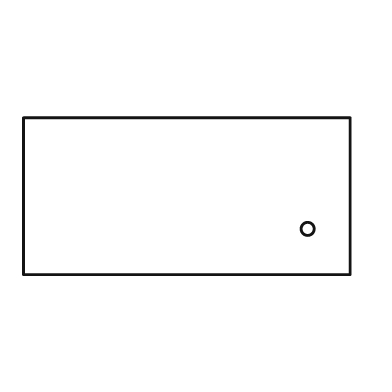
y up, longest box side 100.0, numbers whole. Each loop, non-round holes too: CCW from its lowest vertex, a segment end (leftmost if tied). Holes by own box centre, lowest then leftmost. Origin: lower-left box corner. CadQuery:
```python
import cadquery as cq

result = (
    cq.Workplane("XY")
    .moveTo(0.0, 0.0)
    .lineTo(100.0, 0.0)
    .lineTo(100.0, 48.0)
    .lineTo(0.0, 48.0)
    .close()
    .moveTo(87.0, 14.0)
    .circle(2.0)
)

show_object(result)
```